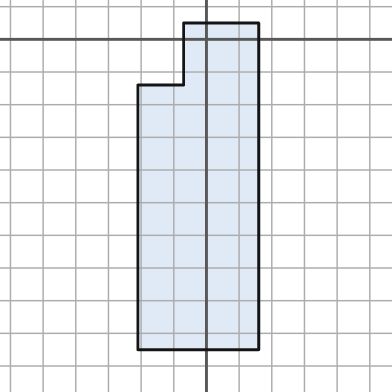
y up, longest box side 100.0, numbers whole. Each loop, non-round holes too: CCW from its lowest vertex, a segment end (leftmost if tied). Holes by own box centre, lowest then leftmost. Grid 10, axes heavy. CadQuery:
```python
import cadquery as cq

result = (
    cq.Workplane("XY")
    .moveTo(-21.0, -95.0)
    .lineTo(16.0, -95.0)
    .lineTo(16.0, 5.0)
    .lineTo(-7.0, 5.0)
    .lineTo(-7.0, -14.0)
    .lineTo(-21.0, -14.0)
    .close()
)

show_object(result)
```